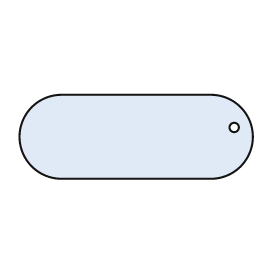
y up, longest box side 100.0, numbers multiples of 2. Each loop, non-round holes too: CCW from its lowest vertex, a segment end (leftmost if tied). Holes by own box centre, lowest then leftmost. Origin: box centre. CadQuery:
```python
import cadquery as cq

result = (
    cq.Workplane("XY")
    .moveTo(-32.0, -18.0)
    .lineTo(32.0, -18.0)
    .threePointArc((50.0, 0.0), (32.0, 18.0))
    .lineTo(-32.0, 18.0)
    .threePointArc((-50.0, 0.0), (-32.0, -18.0))
    .close()
    .moveTo(42.0, 4.0)
    .circle(2.0)
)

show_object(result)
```